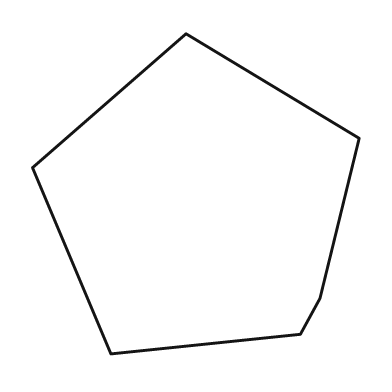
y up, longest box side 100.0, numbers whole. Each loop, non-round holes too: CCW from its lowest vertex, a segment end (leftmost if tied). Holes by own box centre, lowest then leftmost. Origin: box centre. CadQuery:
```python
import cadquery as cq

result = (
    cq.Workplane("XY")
    .moveTo(-26.0, -49.0)
    .lineTo(32.0, -43.0)
    .lineTo(38.0, -32.0)
    .lineTo(50.0, 17.0)
    .lineTo(-3.0, 49.0)
    .lineTo(-50.0, 8.0)
    .close()
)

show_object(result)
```